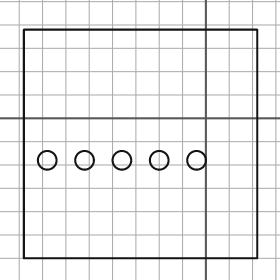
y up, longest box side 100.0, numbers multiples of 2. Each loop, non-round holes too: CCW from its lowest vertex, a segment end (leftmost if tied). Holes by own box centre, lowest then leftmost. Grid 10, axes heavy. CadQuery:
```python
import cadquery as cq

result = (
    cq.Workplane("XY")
    .moveTo(-78.0, -60.0)
    .lineTo(22.0, -60.0)
    .lineTo(22.0, 38.0)
    .lineTo(-78.0, 38.0)
    .close()
    .moveTo(-68.0, -18.0)
    .circle(4.0)
    .moveTo(-52.0, -18.0)
    .circle(4.0)
    .moveTo(-36.0, -18.0)
    .circle(4.0)
    .moveTo(-20.0, -18.0)
    .circle(4.0)
    .moveTo(-4.0, -18.0)
    .circle(4.0)
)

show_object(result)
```